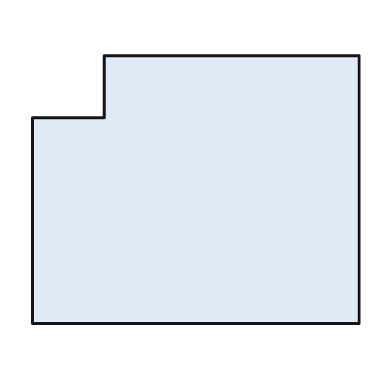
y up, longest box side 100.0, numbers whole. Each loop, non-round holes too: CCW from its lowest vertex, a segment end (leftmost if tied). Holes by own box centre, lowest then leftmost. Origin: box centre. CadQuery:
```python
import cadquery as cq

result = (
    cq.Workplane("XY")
    .moveTo(-50.0, -41.0)
    .lineTo(50.0, -41.0)
    .lineTo(50.0, 41.0)
    .lineTo(-28.0, 41.0)
    .lineTo(-28.0, 22.0)
    .lineTo(-50.0, 22.0)
    .close()
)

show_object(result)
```